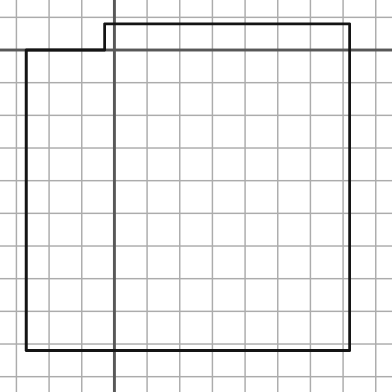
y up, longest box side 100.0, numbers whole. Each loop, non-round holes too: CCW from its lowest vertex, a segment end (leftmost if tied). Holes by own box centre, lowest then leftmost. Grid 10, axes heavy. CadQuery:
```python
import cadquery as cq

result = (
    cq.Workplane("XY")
    .moveTo(-27.0, -92.0)
    .lineTo(72.0, -92.0)
    .lineTo(72.0, 8.0)
    .lineTo(-3.0, 8.0)
    .lineTo(-3.0, 0.0)
    .lineTo(-27.0, 0.0)
    .close()
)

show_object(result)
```